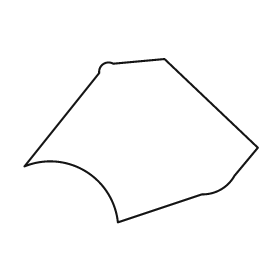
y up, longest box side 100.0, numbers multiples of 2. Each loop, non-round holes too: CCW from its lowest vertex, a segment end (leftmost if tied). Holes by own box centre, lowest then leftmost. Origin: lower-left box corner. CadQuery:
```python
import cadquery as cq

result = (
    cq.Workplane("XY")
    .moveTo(40.0, 0.0)
    .lineTo(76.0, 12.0)
    .threePointArc((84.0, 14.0), (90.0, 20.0))
    .lineTo(100.0, 32.0)
    .lineTo(60.0, 70.0)
    .lineTo(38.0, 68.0)
    .threePointArc((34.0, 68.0), (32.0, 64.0))
    .lineTo(0.0, 24.0)
    .threePointArc((26.0, 22.0), (40.0, 0.0))
    .close()
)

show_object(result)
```